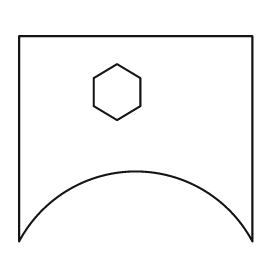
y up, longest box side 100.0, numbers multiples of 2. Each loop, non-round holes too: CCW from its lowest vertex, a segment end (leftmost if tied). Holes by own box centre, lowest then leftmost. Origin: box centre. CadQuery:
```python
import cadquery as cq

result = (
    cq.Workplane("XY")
    .moveTo(-50.0, -44.0)
    .threePointArc((0.0, -14.0), (50.0, -44.0))
    .lineTo(50.0, 44.0)
    .lineTo(-50.0, 44.0)
    .close()
    .moveTo(-8.0, 8.0)
    .lineTo(2.0, 14.0)
    .lineTo(2.0, 26.0)
    .lineTo(-8.0, 32.0)
    .lineTo(-18.0, 26.0)
    .lineTo(-18.0, 14.0)
    .close()
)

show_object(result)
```